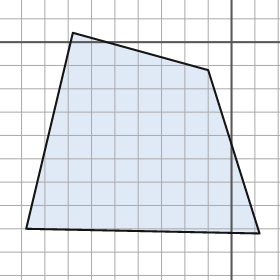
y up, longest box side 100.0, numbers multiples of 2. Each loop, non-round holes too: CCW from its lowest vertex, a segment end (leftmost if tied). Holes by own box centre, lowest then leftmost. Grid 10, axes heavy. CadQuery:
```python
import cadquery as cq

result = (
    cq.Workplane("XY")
    .moveTo(12.0, -82.0)
    .lineTo(-10.0, -12.0)
    .lineTo(-68.0, 4.0)
    .lineTo(-88.0, -80.0)
    .close()
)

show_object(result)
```